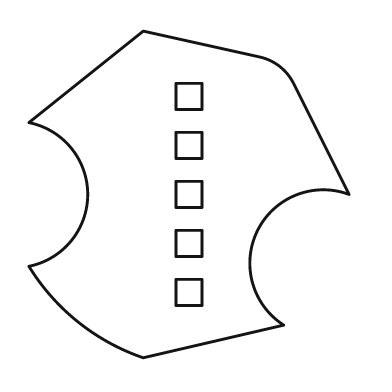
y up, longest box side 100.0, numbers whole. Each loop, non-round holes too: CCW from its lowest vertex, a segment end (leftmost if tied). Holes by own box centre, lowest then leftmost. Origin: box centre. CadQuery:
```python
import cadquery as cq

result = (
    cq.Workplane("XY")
    .moveTo(-14.0, -50.0)
    .lineTo(29.0, -40.0)
    .threePointArc((21.0, -11.0), (49.0, 0.0))
    .lineTo(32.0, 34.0)
    .threePointArc((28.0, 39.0), (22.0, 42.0))
    .lineTo(-14.0, 50.0)
    .lineTo(-49.0, 22.0)
    .threePointArc((-31.0, 0.0), (-49.0, -22.0))
    .threePointArc((-34.0, -39.0), (-14.0, -50.0))
    .close()
    .moveTo(-4.0, -34.0)
    .lineTo(4.0, -34.0)
    .lineTo(4.0, -26.0)
    .lineTo(-4.0, -26.0)
    .close()
    .moveTo(-4.0, -19.0)
    .lineTo(4.0, -19.0)
    .lineTo(4.0, -11.0)
    .lineTo(-4.0, -11.0)
    .close()
    .moveTo(-4.0, -4.0)
    .lineTo(4.0, -4.0)
    .lineTo(4.0, 4.0)
    .lineTo(-4.0, 4.0)
    .close()
    .moveTo(-4.0, 11.0)
    .lineTo(4.0, 11.0)
    .lineTo(4.0, 19.0)
    .lineTo(-4.0, 19.0)
    .close()
    .moveTo(-4.0, 26.0)
    .lineTo(4.0, 26.0)
    .lineTo(4.0, 34.0)
    .lineTo(-4.0, 34.0)
    .close()
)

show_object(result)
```